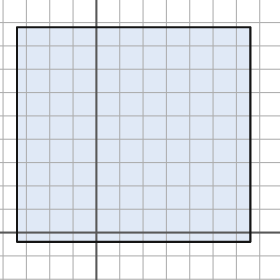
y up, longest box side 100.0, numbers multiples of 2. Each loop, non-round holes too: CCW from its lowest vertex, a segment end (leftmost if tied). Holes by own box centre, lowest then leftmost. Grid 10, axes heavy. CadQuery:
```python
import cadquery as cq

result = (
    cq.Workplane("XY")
    .moveTo(-34.0, -4.0)
    .lineTo(66.0, -4.0)
    .lineTo(66.0, 88.0)
    .lineTo(-34.0, 88.0)
    .close()
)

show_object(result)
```